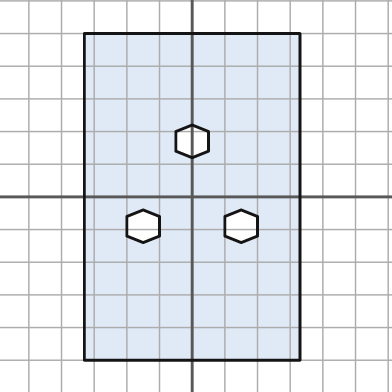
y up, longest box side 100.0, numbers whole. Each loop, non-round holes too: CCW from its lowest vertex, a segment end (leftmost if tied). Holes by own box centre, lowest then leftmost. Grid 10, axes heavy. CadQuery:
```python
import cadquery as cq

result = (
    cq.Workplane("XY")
    .moveTo(-33.0, -50.0)
    .lineTo(33.0, -50.0)
    .lineTo(33.0, 50.0)
    .lineTo(-33.0, 50.0)
    .close()
    .moveTo(-15.0, -14.0)
    .lineTo(-10.0, -12.0)
    .lineTo(-10.0, -6.0)
    .lineTo(-15.0, -4.0)
    .lineTo(-20.0, -6.0)
    .lineTo(-20.0, -12.0)
    .close()
    .moveTo(15.0, -14.0)
    .lineTo(20.0, -12.0)
    .lineTo(20.0, -6.0)
    .lineTo(15.0, -4.0)
    .lineTo(10.0, -6.0)
    .lineTo(10.0, -12.0)
    .close()
    .moveTo(0.0, 12.0)
    .lineTo(5.0, 14.0)
    .lineTo(5.0, 20.0)
    .lineTo(0.0, 22.0)
    .lineTo(-5.0, 20.0)
    .lineTo(-5.0, 14.0)
    .close()
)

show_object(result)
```